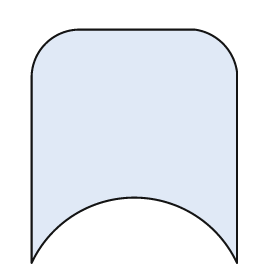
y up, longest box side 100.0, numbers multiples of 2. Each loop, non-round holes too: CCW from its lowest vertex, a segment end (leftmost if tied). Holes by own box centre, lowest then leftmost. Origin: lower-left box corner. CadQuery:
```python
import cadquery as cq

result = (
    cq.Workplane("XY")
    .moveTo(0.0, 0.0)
    .threePointArc((44.0, 28.0), (88.0, 0.0))
    .lineTo(88.0, 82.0)
    .threePointArc((82.0, 94.0), (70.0, 100.0))
    .lineTo(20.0, 100.0)
    .threePointArc((6.0, 94.0), (0.0, 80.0))
    .close()
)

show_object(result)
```